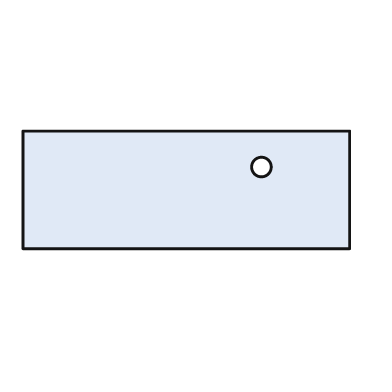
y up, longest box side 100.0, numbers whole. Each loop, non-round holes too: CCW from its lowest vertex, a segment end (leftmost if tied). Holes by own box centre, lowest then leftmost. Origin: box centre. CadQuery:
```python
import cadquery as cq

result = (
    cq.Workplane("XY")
    .moveTo(-50.0, -18.0)
    .lineTo(50.0, -18.0)
    .lineTo(50.0, 18.0)
    .lineTo(-50.0, 18.0)
    .close()
    .moveTo(23.0, 7.0)
    .circle(3.0)
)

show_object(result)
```